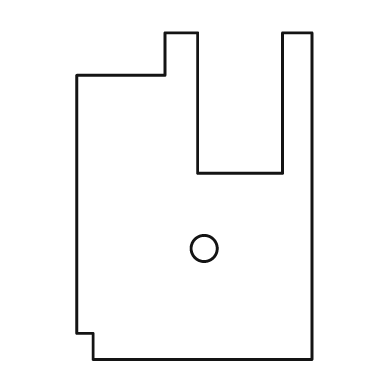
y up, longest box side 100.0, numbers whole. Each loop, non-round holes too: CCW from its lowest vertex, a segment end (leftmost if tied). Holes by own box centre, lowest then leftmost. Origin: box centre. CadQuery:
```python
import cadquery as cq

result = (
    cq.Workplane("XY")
    .moveTo(-31.0, -50.0)
    .lineTo(36.0, -50.0)
    .lineTo(36.0, 50.0)
    .lineTo(27.0, 50.0)
    .lineTo(27.0, 7.0)
    .lineTo(1.0, 7.0)
    .lineTo(1.0, 50.0)
    .lineTo(-9.0, 50.0)
    .lineTo(-9.0, 37.0)
    .lineTo(-36.0, 37.0)
    .lineTo(-36.0, -42.0)
    .lineTo(-31.0, -42.0)
    .close()
    .moveTo(3.0, -16.0)
    .circle(4.0)
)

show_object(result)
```